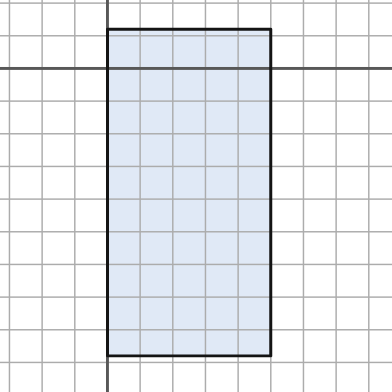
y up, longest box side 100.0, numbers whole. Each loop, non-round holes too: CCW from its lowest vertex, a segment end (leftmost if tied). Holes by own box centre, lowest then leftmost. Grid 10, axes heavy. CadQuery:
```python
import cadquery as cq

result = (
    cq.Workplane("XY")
    .moveTo(0.0, -88.0)
    .lineTo(50.0, -88.0)
    .lineTo(50.0, 12.0)
    .lineTo(0.0, 12.0)
    .close()
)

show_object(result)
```